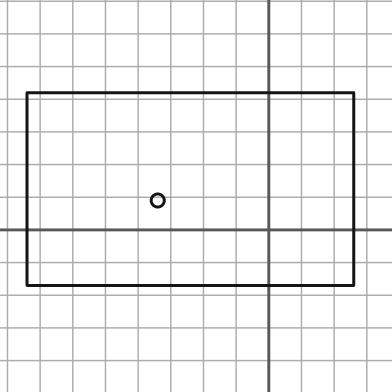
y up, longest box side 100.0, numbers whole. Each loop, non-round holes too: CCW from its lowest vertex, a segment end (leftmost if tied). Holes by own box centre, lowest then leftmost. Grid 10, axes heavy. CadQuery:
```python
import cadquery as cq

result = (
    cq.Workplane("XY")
    .moveTo(-74.0, -17.0)
    .lineTo(26.0, -17.0)
    .lineTo(26.0, 42.0)
    .lineTo(-74.0, 42.0)
    .close()
    .moveTo(-34.0, 9.0)
    .circle(2.0)
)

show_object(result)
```